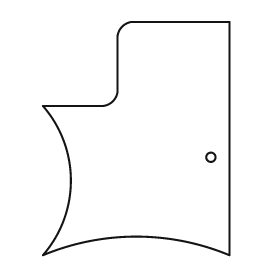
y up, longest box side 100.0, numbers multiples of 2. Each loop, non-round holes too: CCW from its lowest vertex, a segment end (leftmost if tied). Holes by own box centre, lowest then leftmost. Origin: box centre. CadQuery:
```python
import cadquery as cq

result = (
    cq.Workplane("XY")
    .moveTo(-40.0, -50.0)
    .threePointArc((0.0, -42.0), (40.0, -50.0))
    .lineTo(40.0, 50.0)
    .lineTo(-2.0, 50.0)
    .threePointArc((-6.0, 48.0), (-8.0, 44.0))
    .lineTo(-8.0, 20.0)
    .threePointArc((-10.0, 16.0), (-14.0, 14.0))
    .lineTo(-40.0, 14.0)
    .threePointArc((-28.0, -18.0), (-40.0, -50.0))
    .close()
    .moveTo(32.0, -8.0)
    .circle(2.0)
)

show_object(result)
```